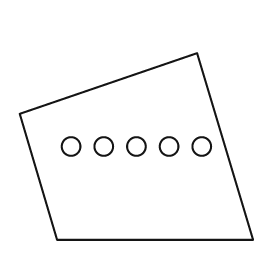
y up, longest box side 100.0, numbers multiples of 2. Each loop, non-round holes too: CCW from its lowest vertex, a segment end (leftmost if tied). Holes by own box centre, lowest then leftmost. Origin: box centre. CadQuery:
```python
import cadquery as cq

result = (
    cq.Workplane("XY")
    .moveTo(-34.0, -40.0)
    .lineTo(50.0, -40.0)
    .lineTo(26.0, 40.0)
    .lineTo(-50.0, 14.0)
    .close()
    .moveTo(-28.0, 0.0)
    .circle(4.0)
    .moveTo(-14.0, 0.0)
    .circle(4.0)
    .moveTo(0.0, 0.0)
    .circle(4.0)
    .moveTo(14.0, 0.0)
    .circle(4.0)
    .moveTo(28.0, 0.0)
    .circle(4.0)
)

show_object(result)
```